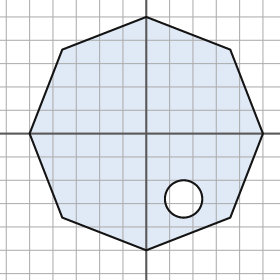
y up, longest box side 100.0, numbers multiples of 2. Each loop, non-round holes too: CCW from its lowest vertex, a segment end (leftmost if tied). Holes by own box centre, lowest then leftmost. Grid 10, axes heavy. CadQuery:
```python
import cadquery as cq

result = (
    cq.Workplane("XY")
    .moveTo(0.0, -50.0)
    .lineTo(36.0, -36.0)
    .lineTo(50.0, 0.0)
    .lineTo(36.0, 36.0)
    .lineTo(0.0, 50.0)
    .lineTo(-36.0, 36.0)
    .lineTo(-50.0, 0.0)
    .lineTo(-36.0, -36.0)
    .close()
    .moveTo(16.0, -28.0)
    .circle(8.0)
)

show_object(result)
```